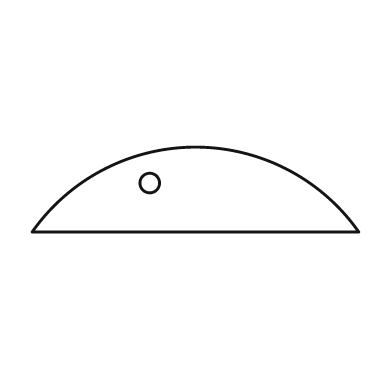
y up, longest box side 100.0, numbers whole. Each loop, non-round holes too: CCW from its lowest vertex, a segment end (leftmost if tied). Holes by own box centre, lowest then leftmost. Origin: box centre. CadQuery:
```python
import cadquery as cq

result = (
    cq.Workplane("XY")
    .moveTo(-50.0, -13.0)
    .lineTo(50.0, -13.0)
    .threePointArc((0.0, 13.0), (-50.0, -13.0))
    .close()
    .moveTo(-14.0, 2.0)
    .circle(3.0)
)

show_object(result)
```